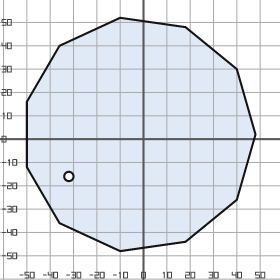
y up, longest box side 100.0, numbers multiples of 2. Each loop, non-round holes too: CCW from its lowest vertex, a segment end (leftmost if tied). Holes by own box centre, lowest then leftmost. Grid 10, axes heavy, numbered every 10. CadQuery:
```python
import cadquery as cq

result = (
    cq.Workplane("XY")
    .moveTo(-10.0, -48.0)
    .lineTo(18.0, -44.0)
    .lineTo(40.0, -26.0)
    .lineTo(48.0, 2.0)
    .lineTo(40.0, 30.0)
    .lineTo(18.0, 48.0)
    .lineTo(-10.0, 52.0)
    .lineTo(-36.0, 40.0)
    .lineTo(-50.0, 16.0)
    .lineTo(-50.0, -12.0)
    .lineTo(-36.0, -36.0)
    .close()
    .moveTo(-32.0, -16.0)
    .circle(2.0)
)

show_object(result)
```